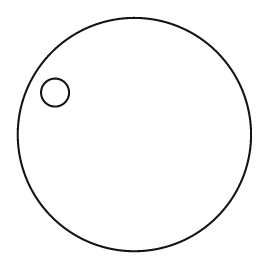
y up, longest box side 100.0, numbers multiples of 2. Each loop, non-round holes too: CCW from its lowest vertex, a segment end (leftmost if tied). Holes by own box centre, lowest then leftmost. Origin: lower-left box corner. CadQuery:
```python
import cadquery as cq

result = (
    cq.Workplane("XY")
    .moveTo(50.0, 50.0)
    .circle(50.0)
    .moveTo(16.0, 68.0)
    .circle(6.0)
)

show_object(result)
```